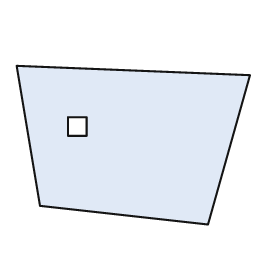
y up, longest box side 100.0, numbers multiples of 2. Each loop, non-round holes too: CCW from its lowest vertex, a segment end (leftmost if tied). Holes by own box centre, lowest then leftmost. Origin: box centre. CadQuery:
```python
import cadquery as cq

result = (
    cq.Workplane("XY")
    .moveTo(32.0, -34.0)
    .lineTo(50.0, 30.0)
    .lineTo(-50.0, 34.0)
    .lineTo(-40.0, -26.0)
    .close()
    .moveTo(-28.0, 4.0)
    .lineTo(-20.0, 4.0)
    .lineTo(-20.0, 12.0)
    .lineTo(-28.0, 12.0)
    .close()
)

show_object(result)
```